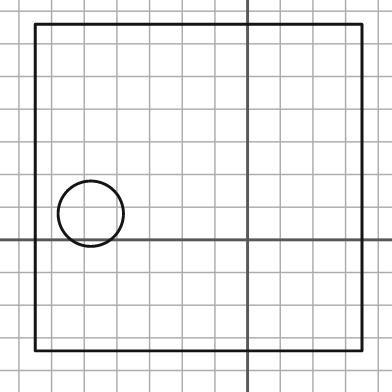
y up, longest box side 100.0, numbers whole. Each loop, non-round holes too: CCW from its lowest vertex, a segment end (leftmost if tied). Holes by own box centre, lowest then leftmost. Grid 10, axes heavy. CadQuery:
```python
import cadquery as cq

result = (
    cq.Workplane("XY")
    .moveTo(-65.0, -34.0)
    .lineTo(35.0, -34.0)
    .lineTo(35.0, 66.0)
    .lineTo(-65.0, 66.0)
    .close()
    .moveTo(-48.0, 8.0)
    .circle(10.0)
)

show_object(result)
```